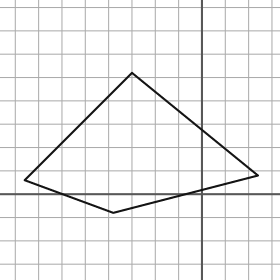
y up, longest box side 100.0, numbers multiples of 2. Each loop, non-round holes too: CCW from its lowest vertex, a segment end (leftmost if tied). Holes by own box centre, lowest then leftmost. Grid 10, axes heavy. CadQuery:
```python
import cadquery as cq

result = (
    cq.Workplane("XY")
    .moveTo(-38.0, -8.0)
    .lineTo(24.0, 8.0)
    .lineTo(-30.0, 52.0)
    .lineTo(-76.0, 6.0)
    .close()
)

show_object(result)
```